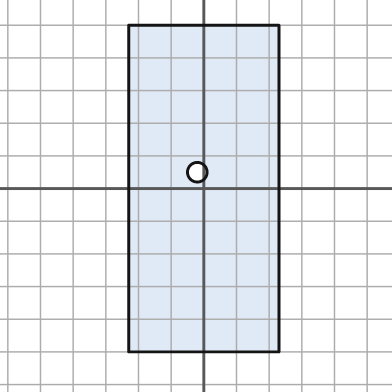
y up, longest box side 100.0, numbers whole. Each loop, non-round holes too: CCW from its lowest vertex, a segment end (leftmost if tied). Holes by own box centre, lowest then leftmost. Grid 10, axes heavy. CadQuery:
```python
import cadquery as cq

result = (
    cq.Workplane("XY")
    .moveTo(-23.0, -50.0)
    .lineTo(23.0, -50.0)
    .lineTo(23.0, 50.0)
    .lineTo(-23.0, 50.0)
    .close()
    .moveTo(-2.0, 5.0)
    .circle(3.0)
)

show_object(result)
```